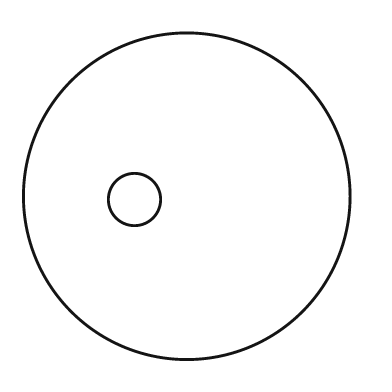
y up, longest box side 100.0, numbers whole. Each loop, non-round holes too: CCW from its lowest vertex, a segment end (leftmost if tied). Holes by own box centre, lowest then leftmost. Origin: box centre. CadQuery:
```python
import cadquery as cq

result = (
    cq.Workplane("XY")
    .moveTo(0.0, 0.0)
    .circle(50.0)
    .moveTo(-16.0, -1.0)
    .circle(8.0)
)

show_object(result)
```